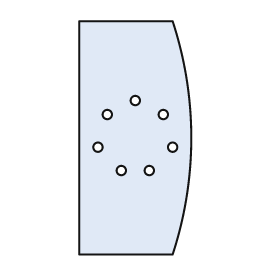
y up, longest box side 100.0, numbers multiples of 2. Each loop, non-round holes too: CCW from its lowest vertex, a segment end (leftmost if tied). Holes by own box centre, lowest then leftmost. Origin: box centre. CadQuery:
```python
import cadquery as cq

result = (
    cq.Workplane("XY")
    .moveTo(-24.0, -50.0)
    .lineTo(16.0, -50.0)
    .threePointArc((24.0, 0.0), (16.0, 50.0))
    .lineTo(-24.0, 50.0)
    .close()
    .moveTo(-6.0, -14.0)
    .circle(2.0)
    .moveTo(6.0, -14.0)
    .circle(2.0)
    .moveTo(-16.0, -4.0)
    .circle(2.0)
    .moveTo(16.0, -4.0)
    .circle(2.0)
    .moveTo(-12.0, 10.0)
    .circle(2.0)
    .moveTo(12.0, 10.0)
    .circle(2.0)
    .moveTo(0.0, 16.0)
    .circle(2.0)
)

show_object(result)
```